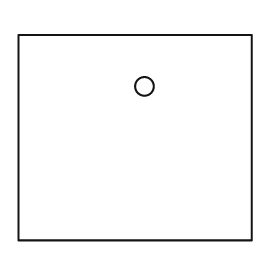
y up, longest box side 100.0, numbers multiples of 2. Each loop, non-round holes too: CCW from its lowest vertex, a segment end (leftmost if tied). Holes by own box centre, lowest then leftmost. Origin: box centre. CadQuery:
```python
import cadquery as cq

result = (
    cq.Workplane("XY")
    .moveTo(-50.0, -44.0)
    .lineTo(50.0, -44.0)
    .lineTo(50.0, 44.0)
    .lineTo(-50.0, 44.0)
    .close()
    .moveTo(4.0, 22.0)
    .circle(4.0)
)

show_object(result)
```